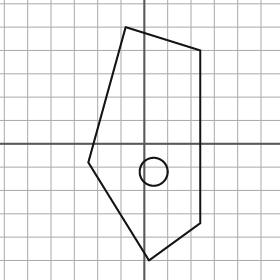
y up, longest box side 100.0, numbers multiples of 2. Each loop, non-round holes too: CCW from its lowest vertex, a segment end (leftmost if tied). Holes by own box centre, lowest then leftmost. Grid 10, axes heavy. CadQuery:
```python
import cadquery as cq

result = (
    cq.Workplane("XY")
    .moveTo(2.0, -50.0)
    .lineTo(24.0, -34.0)
    .lineTo(24.0, 40.0)
    .lineTo(-8.0, 50.0)
    .lineTo(-24.0, -8.0)
    .close()
    .moveTo(4.0, -12.0)
    .circle(6.0)
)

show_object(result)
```